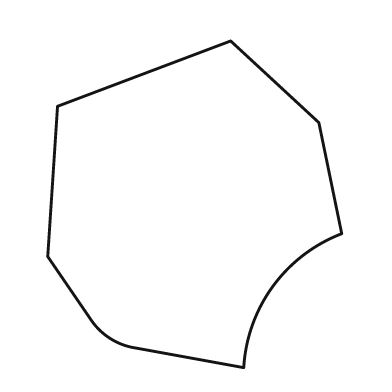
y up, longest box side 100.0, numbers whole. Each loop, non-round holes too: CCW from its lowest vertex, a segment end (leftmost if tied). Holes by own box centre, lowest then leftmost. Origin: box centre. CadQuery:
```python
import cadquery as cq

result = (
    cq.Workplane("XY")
    .moveTo(15.0, -50.0)
    .threePointArc((24.0, -25.0), (45.0, -9.0))
    .lineTo(38.0, 25.0)
    .lineTo(11.0, 50.0)
    .lineTo(-42.0, 30.0)
    .lineTo(-45.0, -16.0)
    .lineTo(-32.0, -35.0)
    .threePointArc((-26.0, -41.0), (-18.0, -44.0))
    .close()
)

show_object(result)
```